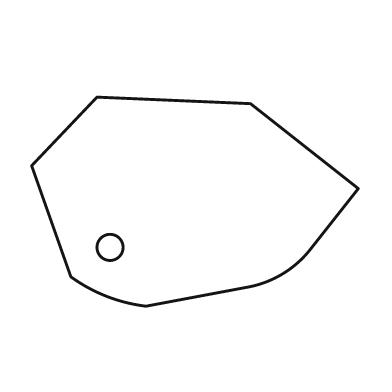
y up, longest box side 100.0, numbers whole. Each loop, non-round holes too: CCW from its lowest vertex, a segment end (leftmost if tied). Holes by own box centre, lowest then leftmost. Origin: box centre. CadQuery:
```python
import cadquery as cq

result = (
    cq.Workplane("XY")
    .moveTo(-15.0, -32.0)
    .lineTo(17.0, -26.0)
    .threePointArc((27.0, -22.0), (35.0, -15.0))
    .lineTo(50.0, 4.0)
    .lineTo(17.0, 30.0)
    .lineTo(-30.0, 32.0)
    .lineTo(-50.0, 11.0)
    .lineTo(-38.0, -23.0)
    .threePointArc((-27.0, -29.0), (-15.0, -32.0))
    .close()
    .moveTo(-26.0, -14.0)
    .circle(4.0)
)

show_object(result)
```